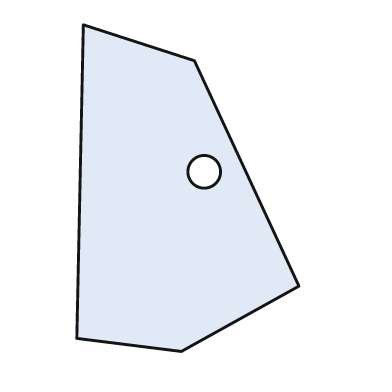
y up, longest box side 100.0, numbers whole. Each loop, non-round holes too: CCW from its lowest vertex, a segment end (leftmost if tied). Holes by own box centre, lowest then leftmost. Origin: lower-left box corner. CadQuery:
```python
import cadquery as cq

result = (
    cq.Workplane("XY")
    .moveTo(32.0, 0.0)
    .lineTo(68.0, 20.0)
    .lineTo(36.0, 89.0)
    .lineTo(2.0, 100.0)
    .lineTo(0.0, 4.0)
    .close()
    .moveTo(39.0, 55.0)
    .circle(5.0)
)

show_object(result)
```